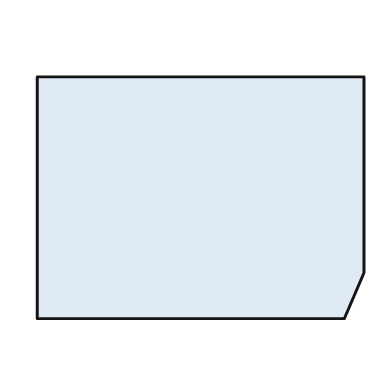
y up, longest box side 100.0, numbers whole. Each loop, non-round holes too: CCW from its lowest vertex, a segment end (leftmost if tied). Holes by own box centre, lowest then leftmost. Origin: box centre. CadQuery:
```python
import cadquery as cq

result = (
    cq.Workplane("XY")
    .moveTo(-50.0, -37.0)
    .lineTo(44.0, -37.0)
    .lineTo(50.0, -23.0)
    .lineTo(50.0, 37.0)
    .lineTo(-50.0, 37.0)
    .close()
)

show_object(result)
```